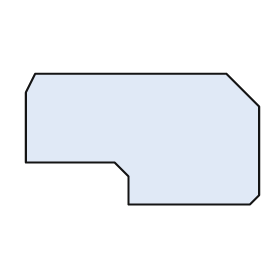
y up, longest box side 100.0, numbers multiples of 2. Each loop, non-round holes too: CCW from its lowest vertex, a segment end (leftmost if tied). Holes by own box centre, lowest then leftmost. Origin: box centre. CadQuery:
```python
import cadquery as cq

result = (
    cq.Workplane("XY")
    .moveTo(-6.0, -28.0)
    .lineTo(46.0, -28.0)
    .lineTo(50.0, -24.0)
    .lineTo(50.0, 14.0)
    .lineTo(36.0, 28.0)
    .lineTo(-46.0, 28.0)
    .lineTo(-50.0, 20.0)
    .lineTo(-50.0, -10.0)
    .lineTo(-12.0, -10.0)
    .lineTo(-6.0, -16.0)
    .close()
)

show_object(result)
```